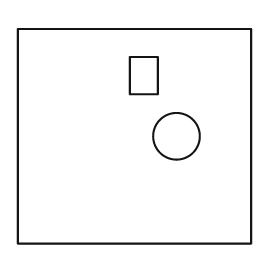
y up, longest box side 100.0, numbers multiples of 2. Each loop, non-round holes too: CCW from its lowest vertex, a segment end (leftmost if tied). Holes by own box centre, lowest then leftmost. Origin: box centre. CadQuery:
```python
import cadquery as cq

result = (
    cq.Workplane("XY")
    .moveTo(-50.0, -46.0)
    .lineTo(50.0, -46.0)
    .lineTo(50.0, 46.0)
    .lineTo(-50.0, 46.0)
    .close()
    .moveTo(18.0, 0.0)
    .circle(10.0)
    .moveTo(-2.0, 18.0)
    .lineTo(10.0, 18.0)
    .lineTo(10.0, 34.0)
    .lineTo(-2.0, 34.0)
    .close()
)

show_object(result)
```